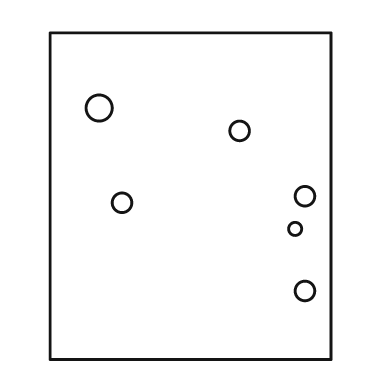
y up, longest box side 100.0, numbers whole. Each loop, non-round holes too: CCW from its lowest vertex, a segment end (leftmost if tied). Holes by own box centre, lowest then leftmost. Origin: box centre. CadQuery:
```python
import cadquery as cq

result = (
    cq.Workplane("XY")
    .moveTo(-43.0, -50.0)
    .lineTo(43.0, -50.0)
    .lineTo(43.0, 50.0)
    .lineTo(-43.0, 50.0)
    .close()
    .moveTo(35.0, -29.0)
    .circle(3.0)
    .moveTo(32.0, -10.0)
    .circle(2.0)
    .moveTo(-21.0, -2.0)
    .circle(3.0)
    .moveTo(35.0, 0.0)
    .circle(3.0)
    .moveTo(15.0, 20.0)
    .circle(3.0)
    .moveTo(-28.0, 27.0)
    .circle(4.0)
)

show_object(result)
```